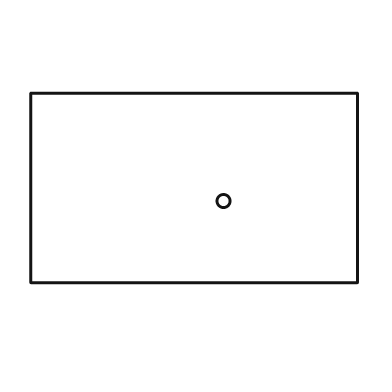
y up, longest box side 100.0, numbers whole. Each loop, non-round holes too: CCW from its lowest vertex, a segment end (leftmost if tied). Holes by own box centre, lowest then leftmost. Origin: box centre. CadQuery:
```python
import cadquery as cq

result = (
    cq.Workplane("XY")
    .moveTo(-50.0, -29.0)
    .lineTo(50.0, -29.0)
    .lineTo(50.0, 29.0)
    .lineTo(-50.0, 29.0)
    .close()
    .moveTo(9.0, -4.0)
    .circle(2.0)
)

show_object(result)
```